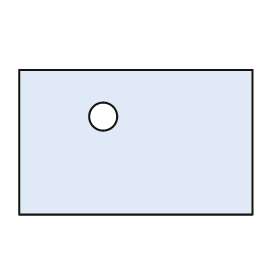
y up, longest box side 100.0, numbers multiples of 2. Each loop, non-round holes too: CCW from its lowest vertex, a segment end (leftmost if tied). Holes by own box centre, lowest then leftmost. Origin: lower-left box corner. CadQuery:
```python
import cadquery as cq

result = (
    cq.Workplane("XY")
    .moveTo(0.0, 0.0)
    .lineTo(100.0, 0.0)
    .lineTo(100.0, 62.0)
    .lineTo(0.0, 62.0)
    .close()
    .moveTo(36.0, 42.0)
    .circle(6.0)
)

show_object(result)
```